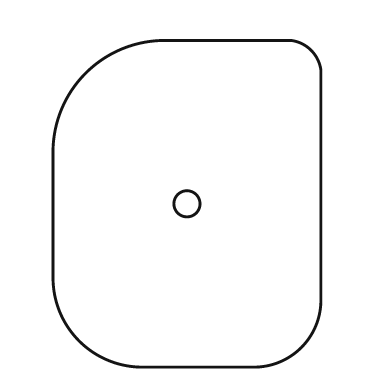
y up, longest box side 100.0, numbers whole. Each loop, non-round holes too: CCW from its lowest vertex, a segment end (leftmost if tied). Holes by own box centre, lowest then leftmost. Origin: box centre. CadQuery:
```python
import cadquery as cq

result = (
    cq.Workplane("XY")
    .moveTo(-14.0, -50.0)
    .lineTo(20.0, -50.0)
    .threePointArc((35.0, -44.0), (41.0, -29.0))
    .lineTo(41.0, 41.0)
    .threePointArc((38.0, 47.0), (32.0, 50.0))
    .lineTo(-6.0, 50.0)
    .threePointArc((-31.0, 40.0), (-41.0, 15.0))
    .lineTo(-41.0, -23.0)
    .threePointArc((-33.0, -42.0), (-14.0, -50.0))
    .close()
    .moveTo(0.0, 0.0)
    .circle(4.0)
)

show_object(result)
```